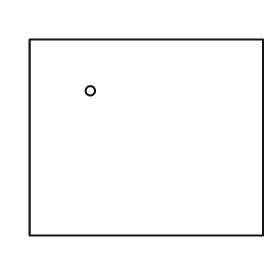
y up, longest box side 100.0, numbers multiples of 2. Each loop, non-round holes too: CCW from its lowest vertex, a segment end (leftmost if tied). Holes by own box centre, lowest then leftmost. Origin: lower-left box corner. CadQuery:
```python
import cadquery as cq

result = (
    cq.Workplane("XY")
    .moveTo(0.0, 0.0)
    .lineTo(100.0, 0.0)
    .lineTo(100.0, 84.0)
    .lineTo(0.0, 84.0)
    .close()
    .moveTo(26.0, 62.0)
    .circle(2.0)
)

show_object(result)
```